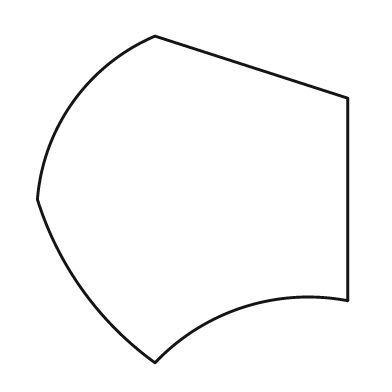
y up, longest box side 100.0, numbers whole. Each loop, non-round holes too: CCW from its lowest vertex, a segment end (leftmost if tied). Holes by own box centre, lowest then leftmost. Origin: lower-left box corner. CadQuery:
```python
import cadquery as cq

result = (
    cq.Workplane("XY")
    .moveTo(36.0, 0.0)
    .threePointArc((63.0, 17.0), (95.0, 19.0))
    .lineTo(95.0, 81.0)
    .lineTo(36.0, 100.0)
    .threePointArc((11.0, 80.0), (0.0, 50.0))
    .threePointArc((14.0, 22.0), (36.0, 0.0))
    .close()
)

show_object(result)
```